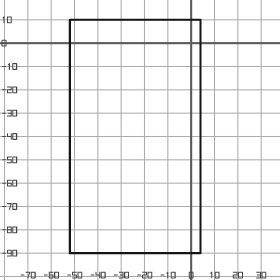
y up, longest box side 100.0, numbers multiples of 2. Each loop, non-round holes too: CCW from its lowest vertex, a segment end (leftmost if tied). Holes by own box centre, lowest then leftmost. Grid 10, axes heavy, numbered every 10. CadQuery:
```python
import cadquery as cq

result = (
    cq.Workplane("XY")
    .moveTo(-52.0, -90.0)
    .lineTo(4.0, -90.0)
    .lineTo(4.0, 10.0)
    .lineTo(-52.0, 10.0)
    .close()
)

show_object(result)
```